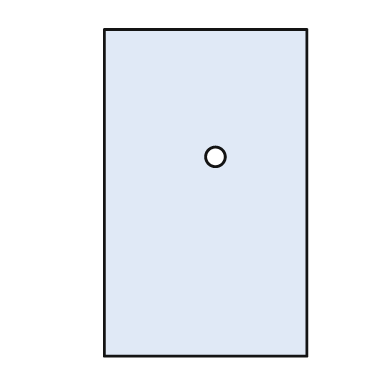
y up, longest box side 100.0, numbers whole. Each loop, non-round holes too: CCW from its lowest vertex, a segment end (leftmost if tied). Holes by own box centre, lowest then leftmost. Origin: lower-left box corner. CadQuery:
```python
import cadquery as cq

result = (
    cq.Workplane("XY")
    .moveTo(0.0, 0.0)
    .lineTo(62.0, 0.0)
    .lineTo(62.0, 100.0)
    .lineTo(0.0, 100.0)
    .close()
    .moveTo(34.0, 61.0)
    .circle(3.0)
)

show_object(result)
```